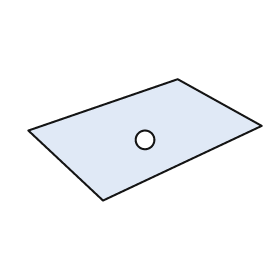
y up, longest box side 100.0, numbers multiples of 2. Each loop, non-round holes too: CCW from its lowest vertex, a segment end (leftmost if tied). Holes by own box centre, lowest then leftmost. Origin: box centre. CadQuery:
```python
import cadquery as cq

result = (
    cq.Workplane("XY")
    .moveTo(-18.0, -26.0)
    .lineTo(50.0, 6.0)
    .lineTo(14.0, 26.0)
    .lineTo(-50.0, 4.0)
    .close()
    .moveTo(0.0, 0.0)
    .circle(4.0)
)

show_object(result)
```